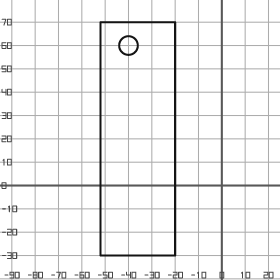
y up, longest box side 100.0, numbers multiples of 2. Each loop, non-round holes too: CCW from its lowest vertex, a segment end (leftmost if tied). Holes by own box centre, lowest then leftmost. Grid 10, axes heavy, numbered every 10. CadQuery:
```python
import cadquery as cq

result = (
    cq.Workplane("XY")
    .moveTo(-52.0, -30.0)
    .lineTo(-20.0, -30.0)
    .lineTo(-20.0, 70.0)
    .lineTo(-52.0, 70.0)
    .close()
    .moveTo(-40.0, 60.0)
    .circle(4.0)
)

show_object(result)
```